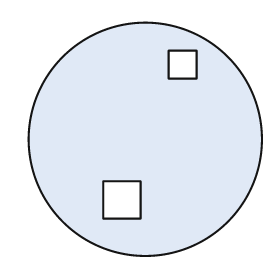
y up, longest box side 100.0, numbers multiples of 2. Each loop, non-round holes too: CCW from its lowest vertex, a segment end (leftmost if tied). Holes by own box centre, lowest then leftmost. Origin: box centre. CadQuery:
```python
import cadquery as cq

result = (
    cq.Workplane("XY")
    .moveTo(0.0, 0.0)
    .circle(50.0)
    .moveTo(-18.0, -34.0)
    .lineTo(-2.0, -34.0)
    .lineTo(-2.0, -18.0)
    .lineTo(-18.0, -18.0)
    .close()
    .moveTo(10.0, 26.0)
    .lineTo(22.0, 26.0)
    .lineTo(22.0, 38.0)
    .lineTo(10.0, 38.0)
    .close()
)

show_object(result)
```